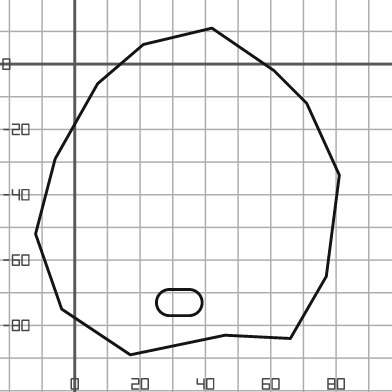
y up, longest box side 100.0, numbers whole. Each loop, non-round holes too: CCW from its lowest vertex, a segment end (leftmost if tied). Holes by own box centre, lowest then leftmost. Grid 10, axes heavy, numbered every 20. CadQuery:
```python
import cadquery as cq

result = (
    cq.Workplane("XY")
    .moveTo(17.0, -89.0)
    .lineTo(46.0, -83.0)
    .lineTo(66.0, -84.0)
    .lineTo(77.0, -65.0)
    .lineTo(81.0, -34.0)
    .lineTo(71.0, -12.0)
    .lineTo(61.0, -2.0)
    .lineTo(42.0, 11.0)
    .lineTo(21.0, 6.0)
    .lineTo(7.0, -6.0)
    .lineTo(-6.0, -29.0)
    .lineTo(-12.0, -52.0)
    .lineTo(-4.0, -75.0)
    .close()
    .moveTo(29.0, -77.0)
    .lineTo(35.0, -77.0)
    .threePointArc((39.0, -73.0), (35.0, -69.0))
    .lineTo(29.0, -69.0)
    .threePointArc((25.0, -73.0), (29.0, -77.0))
    .close()
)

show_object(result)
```